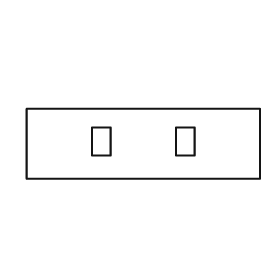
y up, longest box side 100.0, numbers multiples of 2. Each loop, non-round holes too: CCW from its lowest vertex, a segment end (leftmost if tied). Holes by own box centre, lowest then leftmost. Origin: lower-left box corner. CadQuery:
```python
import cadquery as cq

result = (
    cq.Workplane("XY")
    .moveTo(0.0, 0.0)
    .lineTo(100.0, 0.0)
    .lineTo(100.0, 30.0)
    .lineTo(0.0, 30.0)
    .close()
    .moveTo(28.0, 10.0)
    .lineTo(36.0, 10.0)
    .lineTo(36.0, 22.0)
    .lineTo(28.0, 22.0)
    .close()
    .moveTo(64.0, 10.0)
    .lineTo(72.0, 10.0)
    .lineTo(72.0, 22.0)
    .lineTo(64.0, 22.0)
    .close()
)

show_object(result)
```